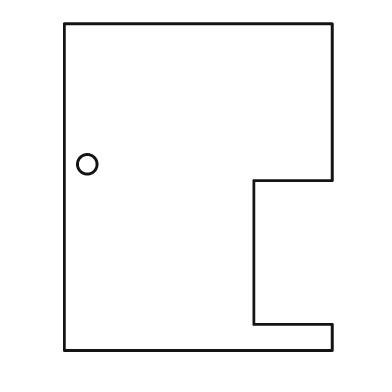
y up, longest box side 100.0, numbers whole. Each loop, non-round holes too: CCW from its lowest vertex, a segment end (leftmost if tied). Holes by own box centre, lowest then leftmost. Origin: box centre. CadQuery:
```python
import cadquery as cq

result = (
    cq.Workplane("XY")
    .moveTo(-41.0, -50.0)
    .lineTo(41.0, -50.0)
    .lineTo(41.0, -42.0)
    .lineTo(17.0, -42.0)
    .lineTo(17.0, 2.0)
    .lineTo(41.0, 2.0)
    .lineTo(41.0, 50.0)
    .lineTo(-41.0, 50.0)
    .close()
    .moveTo(-34.0, 7.0)
    .circle(3.0)
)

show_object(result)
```